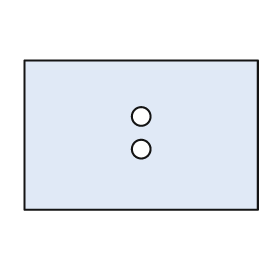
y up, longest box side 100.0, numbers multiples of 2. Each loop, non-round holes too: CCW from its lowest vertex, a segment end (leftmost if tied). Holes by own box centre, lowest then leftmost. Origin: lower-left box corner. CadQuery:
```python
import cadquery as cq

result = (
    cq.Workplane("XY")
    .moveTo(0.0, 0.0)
    .lineTo(100.0, 0.0)
    .lineTo(100.0, 64.0)
    .lineTo(0.0, 64.0)
    .close()
    .moveTo(50.0, 26.0)
    .circle(4.0)
    .moveTo(50.0, 40.0)
    .circle(4.0)
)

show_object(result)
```